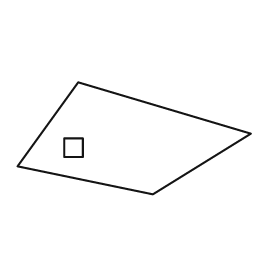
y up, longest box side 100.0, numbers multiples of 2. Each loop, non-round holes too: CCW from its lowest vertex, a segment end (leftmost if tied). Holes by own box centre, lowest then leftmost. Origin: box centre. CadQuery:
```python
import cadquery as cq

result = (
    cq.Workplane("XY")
    .moveTo(8.0, -24.0)
    .lineTo(50.0, 2.0)
    .lineTo(-24.0, 24.0)
    .lineTo(-50.0, -12.0)
    .close()
    .moveTo(-30.0, -8.0)
    .lineTo(-22.0, -8.0)
    .lineTo(-22.0, 0.0)
    .lineTo(-30.0, 0.0)
    .close()
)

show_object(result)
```